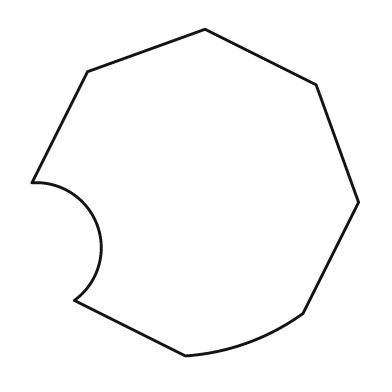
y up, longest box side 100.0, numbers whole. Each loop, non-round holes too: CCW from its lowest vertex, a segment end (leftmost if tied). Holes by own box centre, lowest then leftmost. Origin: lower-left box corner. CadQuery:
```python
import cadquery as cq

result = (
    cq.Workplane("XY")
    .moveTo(47.0, 0.0)
    .threePointArc((66.0, 4.0), (83.0, 13.0))
    .lineTo(100.0, 47.0)
    .lineTo(87.0, 83.0)
    .lineTo(53.0, 100.0)
    .lineTo(17.0, 87.0)
    .lineTo(0.0, 53.0)
    .threePointArc((20.0, 40.0), (13.0, 17.0))
    .close()
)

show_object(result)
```